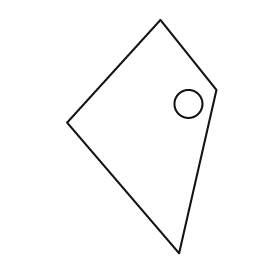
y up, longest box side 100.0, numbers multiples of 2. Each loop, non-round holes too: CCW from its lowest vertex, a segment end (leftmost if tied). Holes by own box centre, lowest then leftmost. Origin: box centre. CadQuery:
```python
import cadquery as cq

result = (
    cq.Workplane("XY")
    .moveTo(16.0, -50.0)
    .lineTo(32.0, 20.0)
    .lineTo(8.0, 50.0)
    .lineTo(-32.0, 6.0)
    .close()
    .moveTo(20.0, 14.0)
    .circle(6.0)
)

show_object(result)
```